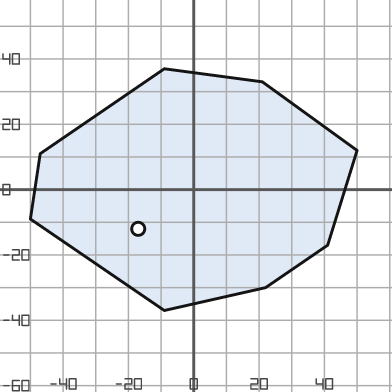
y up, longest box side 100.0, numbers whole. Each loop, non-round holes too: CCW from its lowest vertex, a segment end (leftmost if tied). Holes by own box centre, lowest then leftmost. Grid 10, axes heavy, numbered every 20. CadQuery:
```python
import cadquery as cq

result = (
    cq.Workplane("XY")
    .moveTo(-9.0, -37.0)
    .lineTo(22.0, -30.0)
    .lineTo(41.0, -17.0)
    .lineTo(50.0, 12.0)
    .lineTo(21.0, 33.0)
    .lineTo(-9.0, 37.0)
    .lineTo(-47.0, 11.0)
    .lineTo(-50.0, -9.0)
    .close()
    .moveTo(-17.0, -12.0)
    .circle(2.0)
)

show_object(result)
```